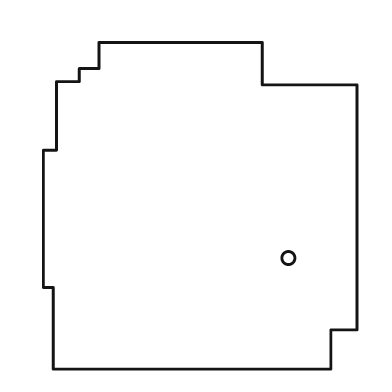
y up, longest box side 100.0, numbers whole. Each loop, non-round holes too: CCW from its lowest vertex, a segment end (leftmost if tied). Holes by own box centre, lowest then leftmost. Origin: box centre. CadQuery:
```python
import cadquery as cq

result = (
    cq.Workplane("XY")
    .moveTo(-45.0, -50.0)
    .lineTo(40.0, -50.0)
    .lineTo(40.0, -38.0)
    .lineTo(48.0, -38.0)
    .lineTo(48.0, 37.0)
    .lineTo(19.0, 37.0)
    .lineTo(19.0, 50.0)
    .lineTo(-31.0, 50.0)
    .lineTo(-31.0, 42.0)
    .lineTo(-37.0, 42.0)
    .lineTo(-37.0, 38.0)
    .lineTo(-44.0, 38.0)
    .lineTo(-44.0, 17.0)
    .lineTo(-48.0, 17.0)
    .lineTo(-48.0, -25.0)
    .lineTo(-45.0, -25.0)
    .close()
    .moveTo(27.0, -16.0)
    .circle(2.0)
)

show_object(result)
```